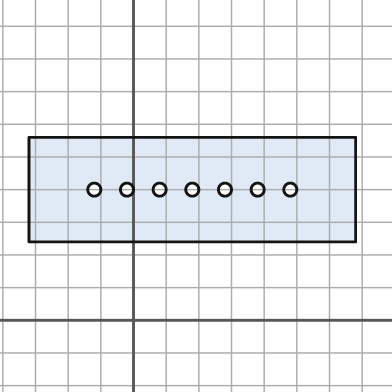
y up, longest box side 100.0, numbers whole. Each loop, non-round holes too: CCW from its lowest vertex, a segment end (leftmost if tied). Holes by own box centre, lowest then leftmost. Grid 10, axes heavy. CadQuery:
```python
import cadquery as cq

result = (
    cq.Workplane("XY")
    .moveTo(-32.0, 24.0)
    .lineTo(68.0, 24.0)
    .lineTo(68.0, 56.0)
    .lineTo(-32.0, 56.0)
    .close()
    .moveTo(-12.0, 40.0)
    .circle(2.0)
    .moveTo(-2.0, 40.0)
    .circle(2.0)
    .moveTo(8.0, 40.0)
    .circle(2.0)
    .moveTo(18.0, 40.0)
    .circle(2.0)
    .moveTo(28.0, 40.0)
    .circle(2.0)
    .moveTo(38.0, 40.0)
    .circle(2.0)
    .moveTo(48.0, 40.0)
    .circle(2.0)
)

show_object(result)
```